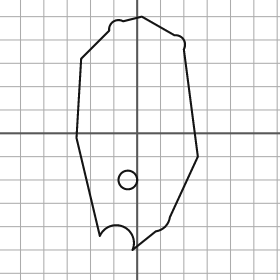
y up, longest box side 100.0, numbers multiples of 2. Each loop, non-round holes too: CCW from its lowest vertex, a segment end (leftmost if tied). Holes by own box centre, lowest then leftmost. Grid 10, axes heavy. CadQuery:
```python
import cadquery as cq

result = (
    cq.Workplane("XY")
    .moveTo(-2.0, -50.0)
    .lineTo(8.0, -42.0)
    .threePointArc((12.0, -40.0), (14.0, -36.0))
    .lineTo(26.0, -10.0)
    .lineTo(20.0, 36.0)
    .threePointArc((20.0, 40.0), (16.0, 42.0))
    .lineTo(2.0, 50.0)
    .lineTo(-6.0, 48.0)
    .threePointArc((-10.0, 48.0), (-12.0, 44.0))
    .lineTo(-24.0, 32.0)
    .lineTo(-26.0, -2.0)
    .lineTo(-16.0, -44.0)
    .threePointArc((-6.0, -40.0), (-2.0, -50.0))
    .close()
    .moveTo(-4.0, -20.0)
    .circle(4.0)
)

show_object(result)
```